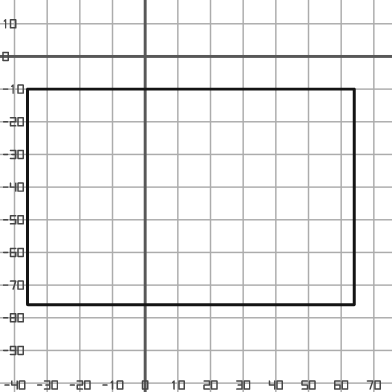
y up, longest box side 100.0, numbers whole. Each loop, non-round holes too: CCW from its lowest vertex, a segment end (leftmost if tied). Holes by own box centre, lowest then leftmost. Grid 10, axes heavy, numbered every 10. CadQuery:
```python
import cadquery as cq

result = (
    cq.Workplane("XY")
    .moveTo(-36.0, -76.0)
    .lineTo(64.0, -76.0)
    .lineTo(64.0, -10.0)
    .lineTo(-36.0, -10.0)
    .close()
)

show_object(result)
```